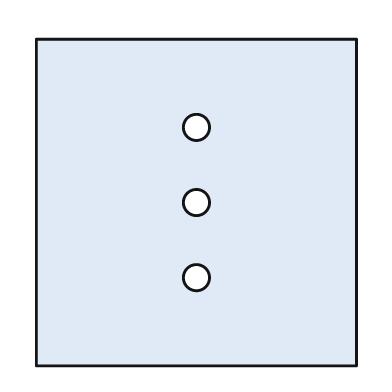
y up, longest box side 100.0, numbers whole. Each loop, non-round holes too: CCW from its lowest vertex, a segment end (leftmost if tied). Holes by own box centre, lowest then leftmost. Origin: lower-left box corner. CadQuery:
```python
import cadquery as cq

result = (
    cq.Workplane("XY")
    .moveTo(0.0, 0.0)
    .lineTo(98.0, 0.0)
    .lineTo(98.0, 100.0)
    .lineTo(0.0, 100.0)
    .close()
    .moveTo(49.0, 27.0)
    .circle(4.0)
    .moveTo(49.0, 50.0)
    .circle(4.0)
    .moveTo(49.0, 73.0)
    .circle(4.0)
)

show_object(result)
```